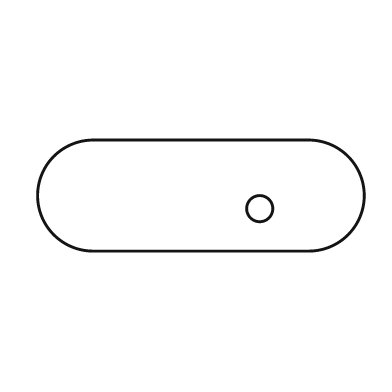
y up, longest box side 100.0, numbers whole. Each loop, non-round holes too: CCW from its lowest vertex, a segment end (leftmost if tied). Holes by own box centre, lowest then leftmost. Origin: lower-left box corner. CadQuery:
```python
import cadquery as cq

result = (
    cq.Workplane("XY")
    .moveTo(17.0, 0.0)
    .lineTo(83.0, 0.0)
    .threePointArc((100.0, 17.0), (83.0, 34.0))
    .lineTo(17.0, 34.0)
    .threePointArc((0.0, 17.0), (17.0, 0.0))
    .close()
    .moveTo(68.0, 13.0)
    .circle(4.0)
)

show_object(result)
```